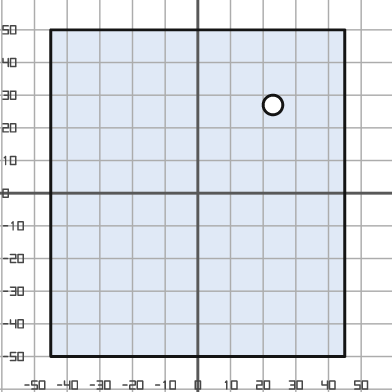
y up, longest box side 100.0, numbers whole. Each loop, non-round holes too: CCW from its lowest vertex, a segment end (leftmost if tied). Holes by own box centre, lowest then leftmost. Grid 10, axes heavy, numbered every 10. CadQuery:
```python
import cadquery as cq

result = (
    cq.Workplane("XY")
    .moveTo(-45.0, -50.0)
    .lineTo(45.0, -50.0)
    .lineTo(45.0, 50.0)
    .lineTo(-45.0, 50.0)
    .close()
    .moveTo(23.0, 27.0)
    .circle(3.0)
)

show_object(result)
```